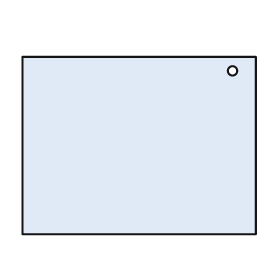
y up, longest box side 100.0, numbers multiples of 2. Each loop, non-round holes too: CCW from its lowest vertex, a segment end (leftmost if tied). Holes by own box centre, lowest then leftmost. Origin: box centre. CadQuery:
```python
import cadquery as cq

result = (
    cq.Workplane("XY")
    .moveTo(-50.0, -38.0)
    .lineTo(50.0, -38.0)
    .lineTo(50.0, 38.0)
    .lineTo(-50.0, 38.0)
    .close()
    .moveTo(40.0, 32.0)
    .circle(2.0)
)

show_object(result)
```